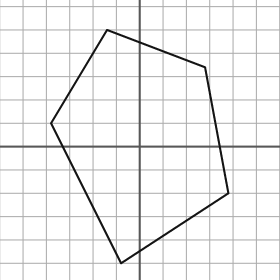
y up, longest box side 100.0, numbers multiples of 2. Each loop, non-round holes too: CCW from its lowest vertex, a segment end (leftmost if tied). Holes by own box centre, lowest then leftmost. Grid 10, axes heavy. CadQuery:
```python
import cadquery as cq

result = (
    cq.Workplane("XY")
    .moveTo(-8.0, -50.0)
    .lineTo(38.0, -20.0)
    .lineTo(28.0, 34.0)
    .lineTo(-14.0, 50.0)
    .lineTo(-38.0, 10.0)
    .close()
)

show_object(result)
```